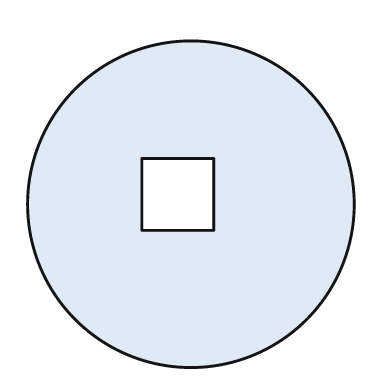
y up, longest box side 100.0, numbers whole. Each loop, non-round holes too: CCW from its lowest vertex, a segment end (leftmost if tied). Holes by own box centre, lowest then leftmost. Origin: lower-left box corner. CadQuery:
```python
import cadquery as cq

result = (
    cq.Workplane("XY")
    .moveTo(50.0, 50.0)
    .circle(50.0)
    .moveTo(35.0, 42.0)
    .lineTo(57.0, 42.0)
    .lineTo(57.0, 64.0)
    .lineTo(35.0, 64.0)
    .close()
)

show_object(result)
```